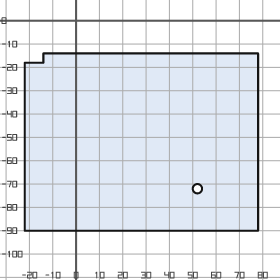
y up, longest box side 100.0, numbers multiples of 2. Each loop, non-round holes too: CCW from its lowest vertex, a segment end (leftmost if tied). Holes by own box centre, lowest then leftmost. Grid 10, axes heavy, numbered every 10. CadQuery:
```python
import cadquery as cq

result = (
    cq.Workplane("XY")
    .moveTo(-22.0, -90.0)
    .lineTo(78.0, -90.0)
    .lineTo(78.0, -14.0)
    .lineTo(-14.0, -14.0)
    .lineTo(-14.0, -18.0)
    .lineTo(-22.0, -18.0)
    .close()
    .moveTo(52.0, -72.0)
    .circle(2.0)
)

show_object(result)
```